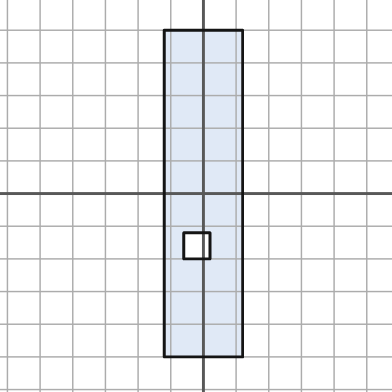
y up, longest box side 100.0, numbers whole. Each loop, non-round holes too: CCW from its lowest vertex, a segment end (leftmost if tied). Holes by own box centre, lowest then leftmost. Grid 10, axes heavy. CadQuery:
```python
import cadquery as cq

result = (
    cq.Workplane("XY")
    .moveTo(-12.0, -50.0)
    .lineTo(12.0, -50.0)
    .lineTo(12.0, 50.0)
    .lineTo(-12.0, 50.0)
    .close()
    .moveTo(-6.0, -20.0)
    .lineTo(2.0, -20.0)
    .lineTo(2.0, -12.0)
    .lineTo(-6.0, -12.0)
    .close()
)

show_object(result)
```